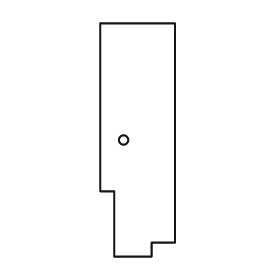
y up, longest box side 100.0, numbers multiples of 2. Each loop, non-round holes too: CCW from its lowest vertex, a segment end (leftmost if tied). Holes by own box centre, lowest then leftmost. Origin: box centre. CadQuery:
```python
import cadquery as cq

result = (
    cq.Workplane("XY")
    .moveTo(-10.0, -50.0)
    .lineTo(6.0, -50.0)
    .lineTo(6.0, -44.0)
    .lineTo(16.0, -44.0)
    .lineTo(16.0, 50.0)
    .lineTo(-16.0, 50.0)
    .lineTo(-16.0, -22.0)
    .lineTo(-10.0, -22.0)
    .close()
    .moveTo(-6.0, 0.0)
    .circle(2.0)
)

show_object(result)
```